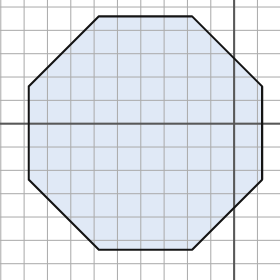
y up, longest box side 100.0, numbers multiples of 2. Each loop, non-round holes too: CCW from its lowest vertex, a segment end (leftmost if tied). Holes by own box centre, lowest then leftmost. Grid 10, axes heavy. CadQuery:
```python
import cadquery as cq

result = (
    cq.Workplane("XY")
    .moveTo(-58.0, -54.0)
    .lineTo(-18.0, -54.0)
    .lineTo(12.0, -24.0)
    .lineTo(12.0, 16.0)
    .lineTo(-18.0, 46.0)
    .lineTo(-58.0, 46.0)
    .lineTo(-88.0, 16.0)
    .lineTo(-88.0, -24.0)
    .close()
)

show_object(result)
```